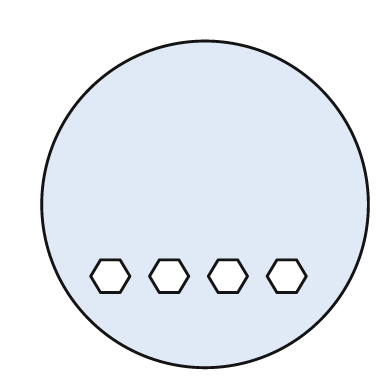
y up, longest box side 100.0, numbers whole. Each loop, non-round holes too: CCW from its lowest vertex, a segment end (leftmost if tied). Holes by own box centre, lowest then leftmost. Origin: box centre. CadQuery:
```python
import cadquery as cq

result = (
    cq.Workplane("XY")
    .moveTo(0.0, 0.0)
    .circle(50.0)
    .moveTo(-32.0, -27.0)
    .lineTo(-26.0, -27.0)
    .lineTo(-23.0, -22.0)
    .lineTo(-26.0, -17.0)
    .lineTo(-32.0, -17.0)
    .lineTo(-35.0, -22.0)
    .close()
    .moveTo(-14.0, -27.0)
    .lineTo(-8.0, -27.0)
    .lineTo(-5.0, -22.0)
    .lineTo(-8.0, -17.0)
    .lineTo(-14.0, -17.0)
    .lineTo(-17.0, -22.0)
    .close()
    .moveTo(4.0, -27.0)
    .lineTo(10.0, -27.0)
    .lineTo(13.0, -22.0)
    .lineTo(10.0, -17.0)
    .lineTo(4.0, -17.0)
    .lineTo(1.0, -22.0)
    .close()
    .moveTo(22.0, -27.0)
    .lineTo(28.0, -27.0)
    .lineTo(31.0, -22.0)
    .lineTo(28.0, -17.0)
    .lineTo(22.0, -17.0)
    .lineTo(19.0, -22.0)
    .close()
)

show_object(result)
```